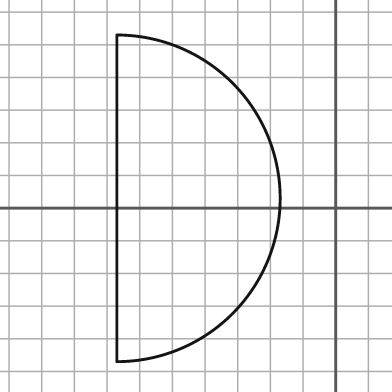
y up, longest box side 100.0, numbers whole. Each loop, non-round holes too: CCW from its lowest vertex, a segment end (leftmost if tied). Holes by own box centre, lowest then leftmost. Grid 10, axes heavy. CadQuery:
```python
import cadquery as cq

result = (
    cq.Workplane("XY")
    .moveTo(-67.0, -47.0)
    .threePointArc((-17.0, 3.0), (-67.0, 53.0))
    .close()
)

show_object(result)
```